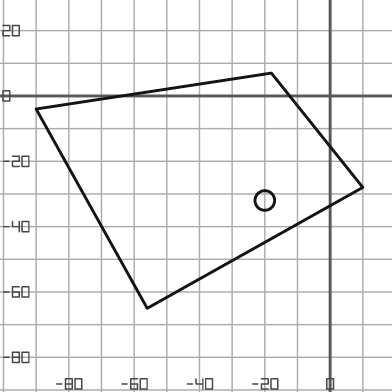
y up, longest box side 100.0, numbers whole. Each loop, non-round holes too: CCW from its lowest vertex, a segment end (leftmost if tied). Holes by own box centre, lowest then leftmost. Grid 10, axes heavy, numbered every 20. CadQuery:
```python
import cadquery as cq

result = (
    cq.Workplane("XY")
    .moveTo(-56.0, -65.0)
    .lineTo(10.0, -28.0)
    .lineTo(-18.0, 7.0)
    .lineTo(-90.0, -4.0)
    .close()
    .moveTo(-20.0, -32.0)
    .circle(3.0)
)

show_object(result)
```